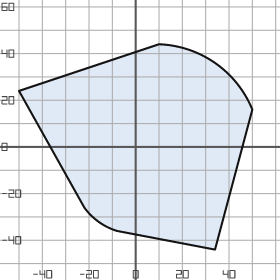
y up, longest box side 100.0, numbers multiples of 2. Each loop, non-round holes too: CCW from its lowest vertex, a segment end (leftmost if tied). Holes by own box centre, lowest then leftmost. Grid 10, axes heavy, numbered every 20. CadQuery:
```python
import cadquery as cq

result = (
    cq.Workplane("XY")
    .moveTo(34.0, -44.0)
    .lineTo(50.0, 16.0)
    .threePointArc((34.0, 36.0), (10.0, 44.0))
    .lineTo(-50.0, 24.0)
    .lineTo(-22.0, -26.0)
    .threePointArc((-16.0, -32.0), (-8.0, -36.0))
    .close()
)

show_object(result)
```